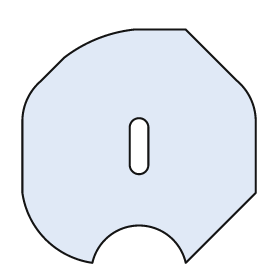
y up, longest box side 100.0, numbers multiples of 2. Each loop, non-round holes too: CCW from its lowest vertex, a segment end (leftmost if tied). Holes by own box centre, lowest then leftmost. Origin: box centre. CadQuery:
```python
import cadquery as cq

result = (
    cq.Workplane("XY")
    .moveTo(-20.0, -50.0)
    .threePointArc((0.0, -34.0), (20.0, -50.0))
    .lineTo(50.0, -20.0)
    .lineTo(50.0, 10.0)
    .threePointArc((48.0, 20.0), (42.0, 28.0))
    .lineTo(20.0, 50.0)
    .lineTo(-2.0, 50.0)
    .threePointArc((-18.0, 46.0), (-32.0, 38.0))
    .lineTo(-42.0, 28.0)
    .threePointArc((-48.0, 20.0), (-50.0, 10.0))
    .lineTo(-50.0, -20.0)
    .threePointArc((-40.0, -40.0), (-20.0, -50.0))
    .close()
    .moveTo(-4.0, -8.0)
    .threePointArc((0.0, -12.0), (4.0, -8.0))
    .lineTo(4.0, 8.0)
    .threePointArc((0.0, 12.0), (-4.0, 8.0))
    .close()
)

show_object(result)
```